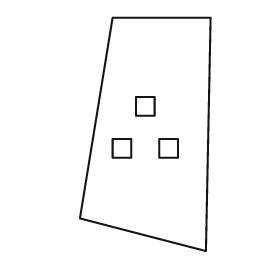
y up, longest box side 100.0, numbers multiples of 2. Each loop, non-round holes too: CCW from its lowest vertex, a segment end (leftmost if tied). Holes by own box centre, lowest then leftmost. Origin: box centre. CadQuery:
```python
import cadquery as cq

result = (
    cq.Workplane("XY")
    .moveTo(26.0, -50.0)
    .lineTo(28.0, 50.0)
    .lineTo(-14.0, 50.0)
    .lineTo(-28.0, -36.0)
    .close()
    .moveTo(-14.0, -10.0)
    .lineTo(-6.0, -10.0)
    .lineTo(-6.0, -2.0)
    .lineTo(-14.0, -2.0)
    .close()
    .moveTo(6.0, -10.0)
    .lineTo(14.0, -10.0)
    .lineTo(14.0, -2.0)
    .lineTo(6.0, -2.0)
    .close()
    .moveTo(-4.0, 8.0)
    .lineTo(4.0, 8.0)
    .lineTo(4.0, 16.0)
    .lineTo(-4.0, 16.0)
    .close()
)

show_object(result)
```